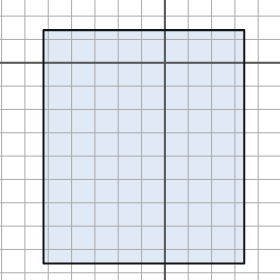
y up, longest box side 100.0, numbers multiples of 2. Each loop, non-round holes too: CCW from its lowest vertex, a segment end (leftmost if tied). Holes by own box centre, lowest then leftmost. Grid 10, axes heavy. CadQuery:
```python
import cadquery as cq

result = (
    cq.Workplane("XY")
    .moveTo(-52.0, -86.0)
    .lineTo(34.0, -86.0)
    .lineTo(34.0, 14.0)
    .lineTo(-52.0, 14.0)
    .close()
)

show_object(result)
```